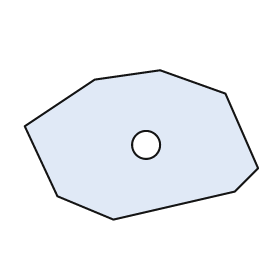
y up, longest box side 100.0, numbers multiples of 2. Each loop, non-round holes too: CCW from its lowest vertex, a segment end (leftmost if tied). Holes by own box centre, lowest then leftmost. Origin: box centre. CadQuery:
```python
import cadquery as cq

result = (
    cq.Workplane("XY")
    .moveTo(-12.0, -32.0)
    .lineTo(40.0, -20.0)
    .lineTo(50.0, -10.0)
    .lineTo(36.0, 22.0)
    .lineTo(8.0, 32.0)
    .lineTo(-20.0, 28.0)
    .lineTo(-50.0, 8.0)
    .lineTo(-36.0, -22.0)
    .close()
    .moveTo(2.0, 0.0)
    .circle(6.0)
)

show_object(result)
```